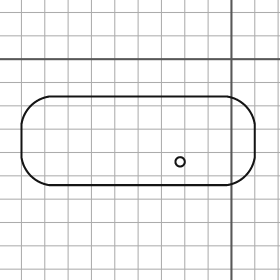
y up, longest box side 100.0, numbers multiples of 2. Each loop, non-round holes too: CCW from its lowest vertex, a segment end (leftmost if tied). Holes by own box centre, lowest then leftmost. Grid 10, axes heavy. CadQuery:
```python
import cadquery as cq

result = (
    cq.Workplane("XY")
    .moveTo(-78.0, -54.0)
    .lineTo(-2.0, -54.0)
    .threePointArc((6.0, -50.0), (10.0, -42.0))
    .lineTo(10.0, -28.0)
    .threePointArc((6.0, -20.0), (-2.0, -16.0))
    .lineTo(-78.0, -16.0)
    .threePointArc((-86.0, -20.0), (-90.0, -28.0))
    .lineTo(-90.0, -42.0)
    .threePointArc((-86.0, -50.0), (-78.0, -54.0))
    .close()
    .moveTo(-22.0, -44.0)
    .circle(2.0)
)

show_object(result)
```